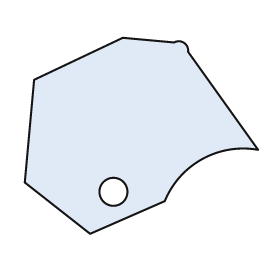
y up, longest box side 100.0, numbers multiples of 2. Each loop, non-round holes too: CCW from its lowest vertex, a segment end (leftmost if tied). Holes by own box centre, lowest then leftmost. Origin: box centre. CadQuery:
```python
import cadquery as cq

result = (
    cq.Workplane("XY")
    .moveTo(-22.0, -42.0)
    .lineTo(10.0, -28.0)
    .threePointArc((26.0, -10.0), (50.0, -6.0))
    .lineTo(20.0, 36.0)
    .threePointArc((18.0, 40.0), (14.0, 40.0))
    .lineTo(-8.0, 42.0)
    .lineTo(-46.0, 24.0)
    .lineTo(-50.0, -20.0)
    .close()
    .moveTo(-12.0, -24.0)
    .circle(6.0)
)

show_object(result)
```